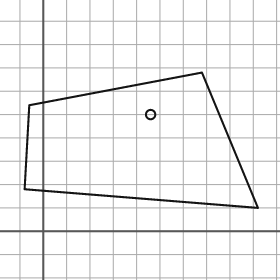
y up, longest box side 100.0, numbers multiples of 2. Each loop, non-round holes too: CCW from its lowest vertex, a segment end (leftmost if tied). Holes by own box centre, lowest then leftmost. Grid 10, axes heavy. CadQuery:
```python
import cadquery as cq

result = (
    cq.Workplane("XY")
    .moveTo(92.0, 10.0)
    .lineTo(68.0, 68.0)
    .lineTo(-6.0, 54.0)
    .lineTo(-8.0, 18.0)
    .close()
    .moveTo(46.0, 50.0)
    .circle(2.0)
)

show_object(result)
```